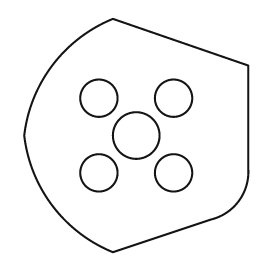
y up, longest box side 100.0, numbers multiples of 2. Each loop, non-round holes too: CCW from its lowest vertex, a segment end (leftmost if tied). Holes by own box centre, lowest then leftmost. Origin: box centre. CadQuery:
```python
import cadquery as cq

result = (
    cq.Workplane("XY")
    .moveTo(-10.0, -50.0)
    .lineTo(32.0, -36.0)
    .threePointArc((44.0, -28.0), (48.0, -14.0))
    .lineTo(48.0, 30.0)
    .lineTo(-10.0, 50.0)
    .threePointArc((-36.0, 30.0), (-48.0, 0.0))
    .threePointArc((-36.0, -30.0), (-10.0, -50.0))
    .close()
    .moveTo(-16.0, -16.0)
    .circle(8.0)
    .moveTo(16.0, -16.0)
    .circle(8.0)
    .moveTo(0.0, 0.0)
    .circle(10.0)
    .moveTo(-16.0, 16.0)
    .circle(8.0)
    .moveTo(16.0, 16.0)
    .circle(8.0)
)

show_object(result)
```